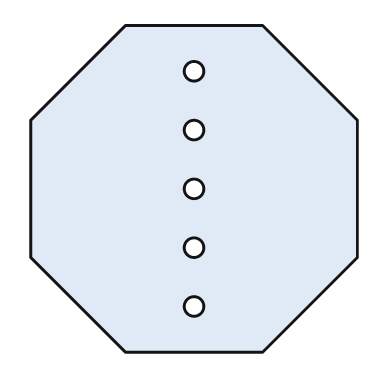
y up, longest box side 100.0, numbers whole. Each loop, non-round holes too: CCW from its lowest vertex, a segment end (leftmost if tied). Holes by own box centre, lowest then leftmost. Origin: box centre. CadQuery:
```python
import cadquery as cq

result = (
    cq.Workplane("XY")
    .moveTo(-21.0, -50.0)
    .lineTo(21.0, -50.0)
    .lineTo(50.0, -21.0)
    .lineTo(50.0, 21.0)
    .lineTo(21.0, 50.0)
    .lineTo(-21.0, 50.0)
    .lineTo(-50.0, 21.0)
    .lineTo(-50.0, -21.0)
    .close()
    .moveTo(0.0, -36.0)
    .circle(3.0)
    .moveTo(0.0, -18.0)
    .circle(3.0)
    .moveTo(0.0, 0.0)
    .circle(3.0)
    .moveTo(0.0, 18.0)
    .circle(3.0)
    .moveTo(0.0, 36.0)
    .circle(3.0)
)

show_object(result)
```